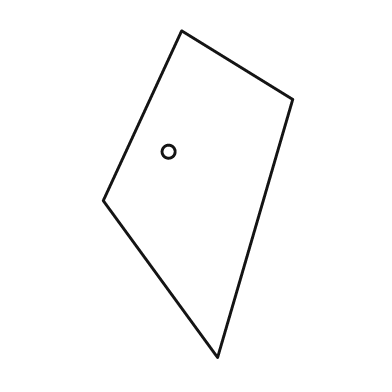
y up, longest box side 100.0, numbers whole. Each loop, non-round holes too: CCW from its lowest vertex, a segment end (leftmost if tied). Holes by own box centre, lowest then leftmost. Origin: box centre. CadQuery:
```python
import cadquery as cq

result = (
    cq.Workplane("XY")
    .moveTo(6.0, -50.0)
    .lineTo(29.0, 29.0)
    .lineTo(-5.0, 50.0)
    .lineTo(-29.0, -2.0)
    .close()
    .moveTo(-9.0, 13.0)
    .circle(2.0)
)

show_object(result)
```